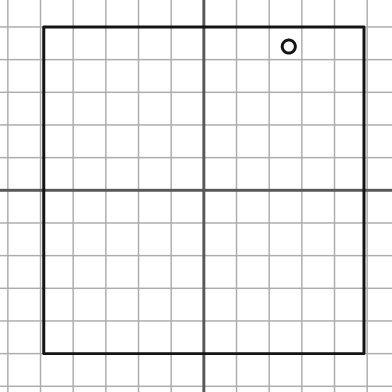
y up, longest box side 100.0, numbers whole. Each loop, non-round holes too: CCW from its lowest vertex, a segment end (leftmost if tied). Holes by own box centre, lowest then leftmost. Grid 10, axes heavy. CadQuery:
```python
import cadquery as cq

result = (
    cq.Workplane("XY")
    .moveTo(-49.0, -50.0)
    .lineTo(49.0, -50.0)
    .lineTo(49.0, 50.0)
    .lineTo(-49.0, 50.0)
    .close()
    .moveTo(26.0, 44.0)
    .circle(2.0)
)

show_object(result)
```